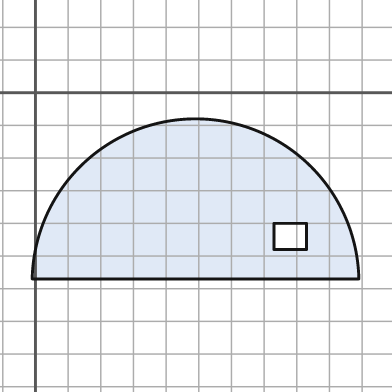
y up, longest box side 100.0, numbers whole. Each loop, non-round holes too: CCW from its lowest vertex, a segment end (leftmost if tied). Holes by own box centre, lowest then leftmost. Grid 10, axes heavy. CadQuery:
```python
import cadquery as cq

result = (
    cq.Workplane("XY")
    .moveTo(-1.0, -57.0)
    .lineTo(99.0, -57.0)
    .threePointArc((49.0, -8.0), (-1.0, -57.0))
    .close()
    .moveTo(73.0, -48.0)
    .lineTo(83.0, -48.0)
    .lineTo(83.0, -40.0)
    .lineTo(73.0, -40.0)
    .close()
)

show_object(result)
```